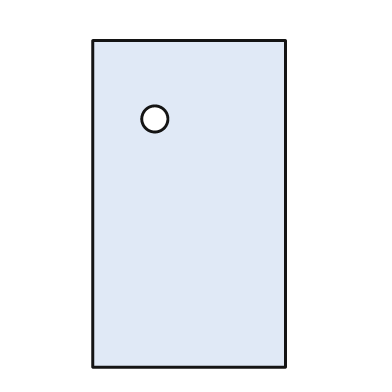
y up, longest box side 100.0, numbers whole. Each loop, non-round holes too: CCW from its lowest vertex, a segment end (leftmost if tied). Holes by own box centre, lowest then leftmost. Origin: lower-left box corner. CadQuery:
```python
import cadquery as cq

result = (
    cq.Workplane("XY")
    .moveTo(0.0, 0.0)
    .lineTo(59.0, 0.0)
    .lineTo(59.0, 100.0)
    .lineTo(0.0, 100.0)
    .close()
    .moveTo(19.0, 76.0)
    .circle(4.0)
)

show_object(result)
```